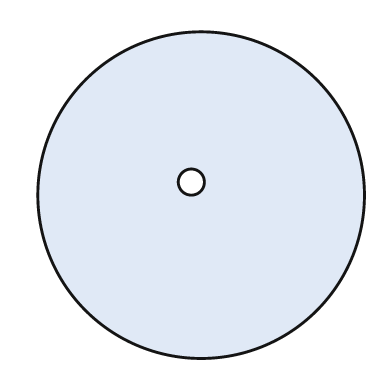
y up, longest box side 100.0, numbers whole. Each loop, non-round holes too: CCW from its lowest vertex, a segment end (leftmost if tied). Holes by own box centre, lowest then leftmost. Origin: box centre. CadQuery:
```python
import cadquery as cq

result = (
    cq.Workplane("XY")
    .moveTo(0.0, 0.0)
    .circle(50.0)
    .moveTo(-3.0, 4.0)
    .circle(4.0)
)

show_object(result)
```